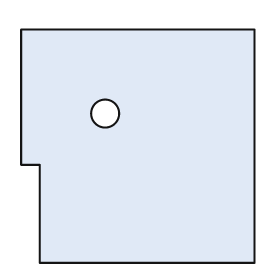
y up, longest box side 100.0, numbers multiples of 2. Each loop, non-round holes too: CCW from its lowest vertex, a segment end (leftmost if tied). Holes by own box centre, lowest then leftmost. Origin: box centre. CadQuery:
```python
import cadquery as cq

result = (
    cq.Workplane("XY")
    .moveTo(-42.0, -50.0)
    .lineTo(50.0, -50.0)
    .lineTo(50.0, 50.0)
    .lineTo(-50.0, 50.0)
    .lineTo(-50.0, -8.0)
    .lineTo(-42.0, -8.0)
    .close()
    .moveTo(-14.0, 14.0)
    .circle(6.0)
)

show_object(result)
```